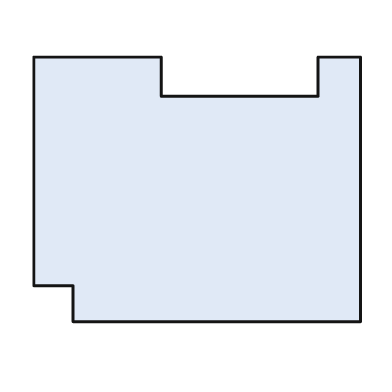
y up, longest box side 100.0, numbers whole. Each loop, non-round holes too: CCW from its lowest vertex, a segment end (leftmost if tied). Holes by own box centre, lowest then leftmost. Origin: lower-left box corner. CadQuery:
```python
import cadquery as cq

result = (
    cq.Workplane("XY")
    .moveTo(12.0, 0.0)
    .lineTo(100.0, 0.0)
    .lineTo(100.0, 81.0)
    .lineTo(87.0, 81.0)
    .lineTo(87.0, 69.0)
    .lineTo(39.0, 69.0)
    .lineTo(39.0, 81.0)
    .lineTo(0.0, 81.0)
    .lineTo(0.0, 11.0)
    .lineTo(12.0, 11.0)
    .close()
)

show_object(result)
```